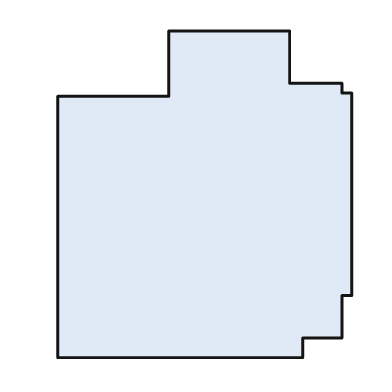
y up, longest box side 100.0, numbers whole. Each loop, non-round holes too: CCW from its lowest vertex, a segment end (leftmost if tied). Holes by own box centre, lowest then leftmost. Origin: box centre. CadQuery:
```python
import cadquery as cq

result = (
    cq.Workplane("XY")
    .moveTo(-45.0, -50.0)
    .lineTo(30.0, -50.0)
    .lineTo(30.0, -44.0)
    .lineTo(42.0, -44.0)
    .lineTo(42.0, -31.0)
    .lineTo(45.0, -31.0)
    .lineTo(45.0, 31.0)
    .lineTo(42.0, 31.0)
    .lineTo(42.0, 34.0)
    .lineTo(26.0, 34.0)
    .lineTo(26.0, 50.0)
    .lineTo(-11.0, 50.0)
    .lineTo(-11.0, 30.0)
    .lineTo(-45.0, 30.0)
    .close()
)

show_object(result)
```